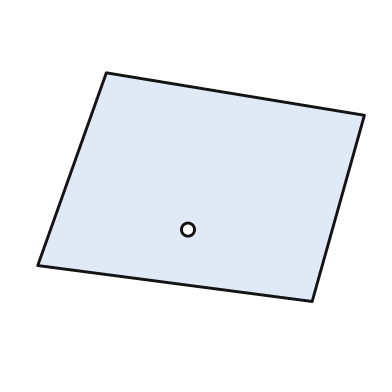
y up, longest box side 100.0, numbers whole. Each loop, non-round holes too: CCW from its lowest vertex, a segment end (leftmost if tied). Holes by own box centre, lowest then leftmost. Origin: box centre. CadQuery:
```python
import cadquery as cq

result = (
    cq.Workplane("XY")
    .moveTo(34.0, -35.0)
    .lineTo(50.0, 22.0)
    .lineTo(-29.0, 35.0)
    .lineTo(-50.0, -24.0)
    .close()
    .moveTo(-4.0, -13.0)
    .circle(2.0)
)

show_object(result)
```